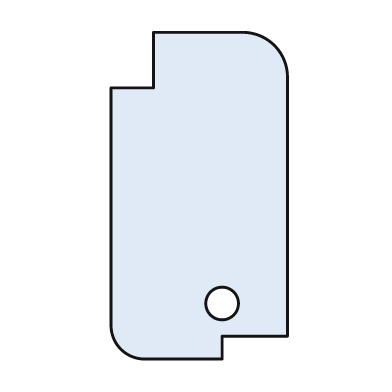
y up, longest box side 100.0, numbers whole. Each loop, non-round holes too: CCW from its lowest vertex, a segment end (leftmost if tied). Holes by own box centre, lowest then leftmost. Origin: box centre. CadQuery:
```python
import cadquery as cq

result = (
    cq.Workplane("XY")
    .moveTo(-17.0, -50.0)
    .lineTo(7.0, -50.0)
    .lineTo(7.0, -43.0)
    .lineTo(27.0, -43.0)
    .lineTo(27.0, 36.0)
    .threePointArc((23.0, 46.0), (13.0, 50.0))
    .lineTo(-14.0, 50.0)
    .lineTo(-14.0, 33.0)
    .lineTo(-27.0, 33.0)
    .lineTo(-27.0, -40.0)
    .threePointArc((-24.0, -47.0), (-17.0, -50.0))
    .close()
    .moveTo(7.0, -33.0)
    .circle(5.0)
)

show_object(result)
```